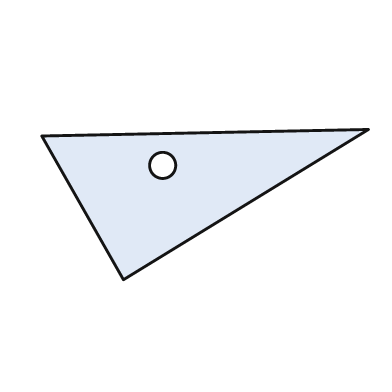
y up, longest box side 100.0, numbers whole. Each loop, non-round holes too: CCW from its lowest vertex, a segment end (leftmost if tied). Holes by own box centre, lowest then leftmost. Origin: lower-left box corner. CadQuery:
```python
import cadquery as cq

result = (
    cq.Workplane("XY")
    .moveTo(25.0, 0.0)
    .lineTo(100.0, 46.0)
    .lineTo(0.0, 44.0)
    .close()
    .moveTo(37.0, 35.0)
    .circle(4.0)
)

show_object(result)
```